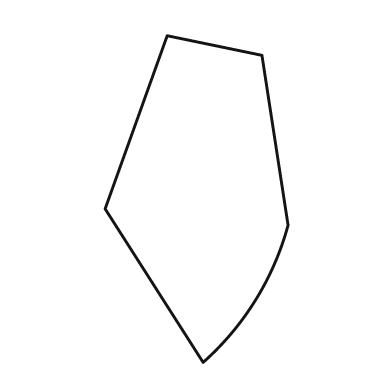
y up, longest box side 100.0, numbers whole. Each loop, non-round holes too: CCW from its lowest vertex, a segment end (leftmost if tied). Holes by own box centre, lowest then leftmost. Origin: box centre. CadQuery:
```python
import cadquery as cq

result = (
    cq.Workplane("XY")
    .moveTo(2.0, -50.0)
    .threePointArc((18.0, -31.0), (28.0, -8.0))
    .lineTo(20.0, 44.0)
    .lineTo(-9.0, 50.0)
    .lineTo(-28.0, -3.0)
    .close()
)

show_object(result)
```